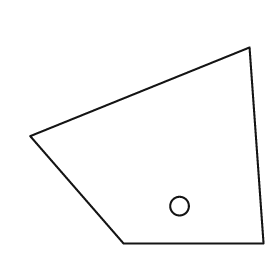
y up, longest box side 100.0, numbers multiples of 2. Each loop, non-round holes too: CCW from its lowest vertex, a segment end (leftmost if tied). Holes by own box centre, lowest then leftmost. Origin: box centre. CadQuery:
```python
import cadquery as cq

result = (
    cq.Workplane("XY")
    .moveTo(-10.0, -42.0)
    .lineTo(50.0, -42.0)
    .lineTo(44.0, 42.0)
    .lineTo(-50.0, 4.0)
    .close()
    .moveTo(14.0, -26.0)
    .circle(4.0)
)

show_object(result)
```